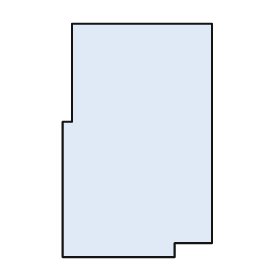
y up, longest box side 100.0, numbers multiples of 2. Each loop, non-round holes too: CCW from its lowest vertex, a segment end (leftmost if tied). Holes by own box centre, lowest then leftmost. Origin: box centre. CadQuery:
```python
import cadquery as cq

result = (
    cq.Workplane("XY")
    .moveTo(-32.0, -50.0)
    .lineTo(16.0, -50.0)
    .lineTo(16.0, -44.0)
    .lineTo(32.0, -44.0)
    .lineTo(32.0, 50.0)
    .lineTo(-28.0, 50.0)
    .lineTo(-28.0, 8.0)
    .lineTo(-32.0, 8.0)
    .close()
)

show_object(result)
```